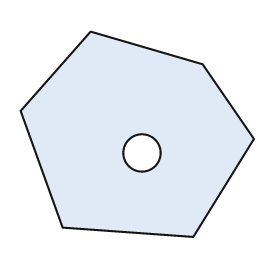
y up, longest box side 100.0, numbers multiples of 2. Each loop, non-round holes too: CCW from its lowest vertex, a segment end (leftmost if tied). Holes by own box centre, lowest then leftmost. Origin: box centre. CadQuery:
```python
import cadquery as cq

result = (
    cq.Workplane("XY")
    .moveTo(24.0, -44.0)
    .lineTo(50.0, -2.0)
    .lineTo(28.0, 30.0)
    .lineTo(-20.0, 44.0)
    .lineTo(-50.0, 10.0)
    .lineTo(-32.0, -40.0)
    .close()
    .moveTo(2.0, -8.0)
    .circle(8.0)
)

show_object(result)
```